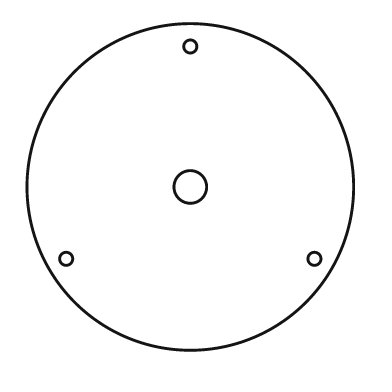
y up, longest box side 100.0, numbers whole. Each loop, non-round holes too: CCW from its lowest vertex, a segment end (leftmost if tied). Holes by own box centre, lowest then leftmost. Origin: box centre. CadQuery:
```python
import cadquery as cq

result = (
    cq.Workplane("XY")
    .moveTo(0.0, 0.0)
    .circle(50.0)
    .moveTo(-38.0, -22.0)
    .circle(2.0)
    .moveTo(38.0, -22.0)
    .circle(2.0)
    .moveTo(0.0, 0.0)
    .circle(5.0)
    .moveTo(0.0, 43.0)
    .circle(2.0)
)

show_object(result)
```